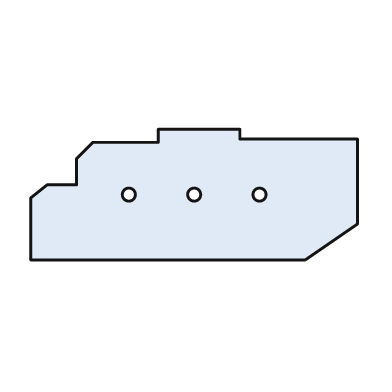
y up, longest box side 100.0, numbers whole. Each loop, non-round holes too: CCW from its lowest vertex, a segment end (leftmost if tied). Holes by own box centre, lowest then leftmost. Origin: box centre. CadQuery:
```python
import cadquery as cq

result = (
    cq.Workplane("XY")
    .moveTo(-50.0, -20.0)
    .lineTo(34.0, -20.0)
    .lineTo(50.0, -9.0)
    .lineTo(50.0, 17.0)
    .lineTo(14.0, 17.0)
    .lineTo(14.0, 20.0)
    .lineTo(-11.0, 20.0)
    .lineTo(-11.0, 16.0)
    .lineTo(-31.0, 16.0)
    .lineTo(-36.0, 11.0)
    .lineTo(-36.0, 3.0)
    .lineTo(-45.0, 3.0)
    .lineTo(-50.0, -1.0)
    .close()
    .moveTo(-20.0, 0.0)
    .circle(2.0)
    .moveTo(0.0, 0.0)
    .circle(2.0)
    .moveTo(20.0, 0.0)
    .circle(2.0)
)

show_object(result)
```